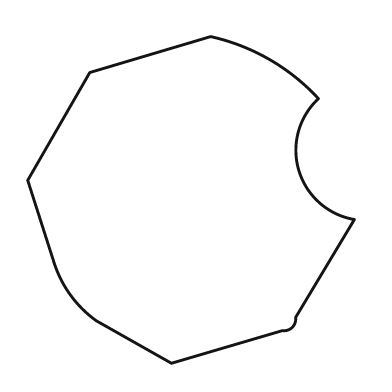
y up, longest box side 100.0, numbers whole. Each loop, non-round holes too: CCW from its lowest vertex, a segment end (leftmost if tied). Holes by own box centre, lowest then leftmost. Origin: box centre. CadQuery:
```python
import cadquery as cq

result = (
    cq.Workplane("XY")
    .moveTo(-6.0, -50.0)
    .lineTo(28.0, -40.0)
    .threePointArc((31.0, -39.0), (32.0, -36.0))
    .lineTo(50.0, -6.0)
    .threePointArc((33.0, 9.0), (39.0, 31.0))
    .threePointArc((24.0, 43.0), (6.0, 50.0))
    .lineTo(-31.0, 39.0)
    .lineTo(-50.0, 6.0)
    .lineTo(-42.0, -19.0)
    .threePointArc((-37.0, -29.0), (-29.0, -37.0))
    .close()
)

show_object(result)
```